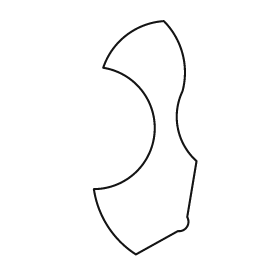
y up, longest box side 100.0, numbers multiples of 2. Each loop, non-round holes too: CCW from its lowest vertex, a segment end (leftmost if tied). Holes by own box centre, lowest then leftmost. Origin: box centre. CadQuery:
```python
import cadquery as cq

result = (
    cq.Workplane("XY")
    .moveTo(-4.0, -50.0)
    .lineTo(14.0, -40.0)
    .threePointArc((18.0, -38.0), (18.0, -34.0))
    .lineTo(22.0, -10.0)
    .threePointArc((14.0, 4.0), (16.0, 20.0))
    .threePointArc((16.0, 36.0), (8.0, 50.0))
    .threePointArc((-8.0, 44.0), (-18.0, 30.0))
    .threePointArc((4.0, 2.0), (-22.0, -22.0))
    .threePointArc((-16.0, -38.0), (-4.0, -50.0))
    .close()
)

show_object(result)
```